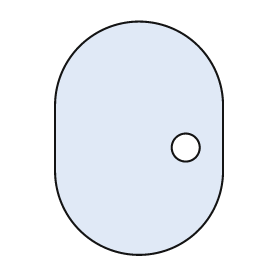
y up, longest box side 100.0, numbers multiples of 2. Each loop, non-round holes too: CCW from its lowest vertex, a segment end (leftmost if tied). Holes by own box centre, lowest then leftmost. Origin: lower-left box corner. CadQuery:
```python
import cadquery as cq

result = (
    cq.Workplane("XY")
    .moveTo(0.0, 36.0)
    .threePointArc((36.0, 0.0), (72.0, 36.0))
    .lineTo(72.0, 64.0)
    .threePointArc((36.0, 100.0), (0.0, 64.0))
    .close()
    .moveTo(56.0, 46.0)
    .circle(6.0)
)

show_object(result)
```